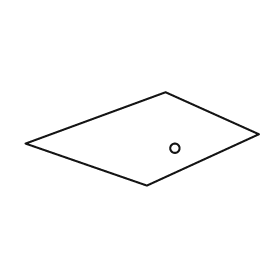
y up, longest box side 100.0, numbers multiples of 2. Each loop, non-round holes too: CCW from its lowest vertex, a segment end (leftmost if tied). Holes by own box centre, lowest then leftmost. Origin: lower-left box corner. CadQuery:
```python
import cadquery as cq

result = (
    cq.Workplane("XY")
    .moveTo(52.0, 0.0)
    .lineTo(100.0, 22.0)
    .lineTo(60.0, 40.0)
    .lineTo(0.0, 18.0)
    .close()
    .moveTo(64.0, 16.0)
    .circle(2.0)
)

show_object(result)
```